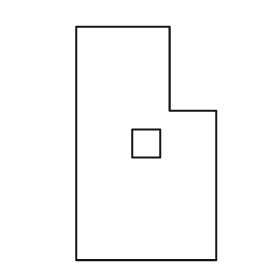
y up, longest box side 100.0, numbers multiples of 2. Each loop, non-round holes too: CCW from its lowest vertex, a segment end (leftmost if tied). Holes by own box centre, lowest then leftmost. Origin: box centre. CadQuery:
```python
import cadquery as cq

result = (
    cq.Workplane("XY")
    .moveTo(-30.0, -50.0)
    .lineTo(30.0, -50.0)
    .lineTo(30.0, 14.0)
    .lineTo(10.0, 14.0)
    .lineTo(10.0, 50.0)
    .lineTo(-30.0, 50.0)
    .close()
    .moveTo(-6.0, -6.0)
    .lineTo(6.0, -6.0)
    .lineTo(6.0, 6.0)
    .lineTo(-6.0, 6.0)
    .close()
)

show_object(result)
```